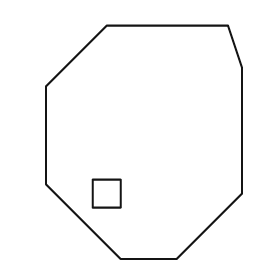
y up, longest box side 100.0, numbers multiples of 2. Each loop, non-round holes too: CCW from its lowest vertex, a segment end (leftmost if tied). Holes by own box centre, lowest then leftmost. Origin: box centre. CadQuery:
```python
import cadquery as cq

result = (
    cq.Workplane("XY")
    .moveTo(-10.0, -50.0)
    .lineTo(14.0, -50.0)
    .lineTo(42.0, -22.0)
    .lineTo(42.0, 32.0)
    .lineTo(36.0, 50.0)
    .lineTo(-16.0, 50.0)
    .lineTo(-42.0, 24.0)
    .lineTo(-42.0, -18.0)
    .close()
    .moveTo(-22.0, -28.0)
    .lineTo(-10.0, -28.0)
    .lineTo(-10.0, -16.0)
    .lineTo(-22.0, -16.0)
    .close()
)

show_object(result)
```